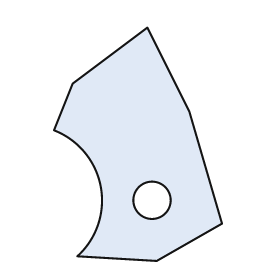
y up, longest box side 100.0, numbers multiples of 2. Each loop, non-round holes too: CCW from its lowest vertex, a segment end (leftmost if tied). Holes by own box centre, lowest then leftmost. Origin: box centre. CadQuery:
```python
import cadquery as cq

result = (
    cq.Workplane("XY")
    .moveTo(8.0, -50.0)
    .lineTo(36.0, -34.0)
    .lineTo(22.0, 14.0)
    .lineTo(4.0, 50.0)
    .lineTo(-28.0, 26.0)
    .lineTo(-36.0, 6.0)
    .threePointArc((-16.0, -18.0), (-26.0, -48.0))
    .close()
    .moveTo(6.0, -24.0)
    .circle(8.0)
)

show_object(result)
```